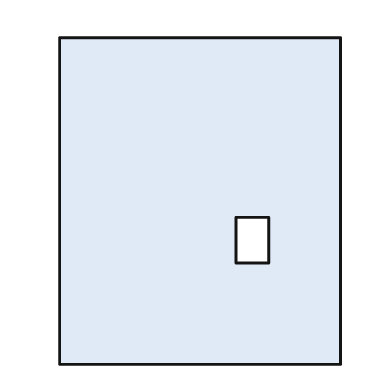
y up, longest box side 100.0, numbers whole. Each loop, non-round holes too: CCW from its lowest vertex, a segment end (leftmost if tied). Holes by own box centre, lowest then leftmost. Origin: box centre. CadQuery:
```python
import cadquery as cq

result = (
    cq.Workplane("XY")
    .moveTo(-43.0, -50.0)
    .lineTo(43.0, -50.0)
    .lineTo(43.0, 50.0)
    .lineTo(-43.0, 50.0)
    .close()
    .moveTo(11.0, -19.0)
    .lineTo(21.0, -19.0)
    .lineTo(21.0, -5.0)
    .lineTo(11.0, -5.0)
    .close()
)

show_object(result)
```